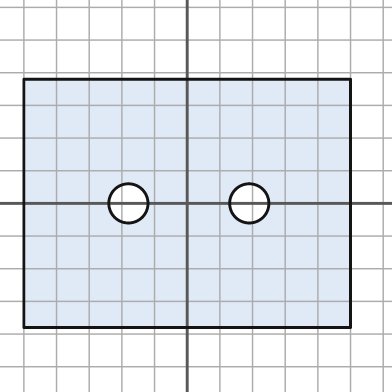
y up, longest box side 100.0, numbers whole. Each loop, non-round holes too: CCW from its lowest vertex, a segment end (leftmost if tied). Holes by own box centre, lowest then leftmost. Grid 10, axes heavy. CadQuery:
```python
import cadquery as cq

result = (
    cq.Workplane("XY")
    .moveTo(-50.0, -38.0)
    .lineTo(50.0, -38.0)
    .lineTo(50.0, 38.0)
    .lineTo(-50.0, 38.0)
    .close()
    .moveTo(-18.0, 0.0)
    .circle(6.0)
    .moveTo(19.0, 0.0)
    .circle(6.0)
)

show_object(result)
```